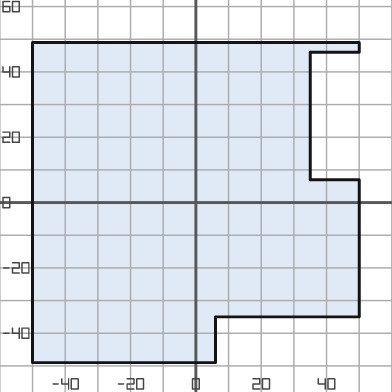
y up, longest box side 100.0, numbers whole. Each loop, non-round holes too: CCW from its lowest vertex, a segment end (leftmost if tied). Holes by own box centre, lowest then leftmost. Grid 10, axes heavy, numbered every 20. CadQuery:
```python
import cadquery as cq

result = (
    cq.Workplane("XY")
    .moveTo(-50.0, -49.0)
    .lineTo(6.0, -49.0)
    .lineTo(6.0, -35.0)
    .lineTo(50.0, -35.0)
    .lineTo(50.0, 7.0)
    .lineTo(35.0, 7.0)
    .lineTo(35.0, 46.0)
    .lineTo(50.0, 46.0)
    .lineTo(50.0, 49.0)
    .lineTo(-50.0, 49.0)
    .close()
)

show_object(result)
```